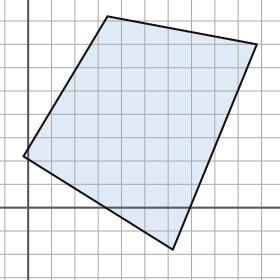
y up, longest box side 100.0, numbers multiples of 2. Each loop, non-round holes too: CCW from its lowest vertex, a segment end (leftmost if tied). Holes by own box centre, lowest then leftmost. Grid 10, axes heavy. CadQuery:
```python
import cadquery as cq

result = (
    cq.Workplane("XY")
    .moveTo(62.0, -18.0)
    .lineTo(98.0, 70.0)
    .lineTo(34.0, 82.0)
    .lineTo(-2.0, 22.0)
    .close()
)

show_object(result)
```